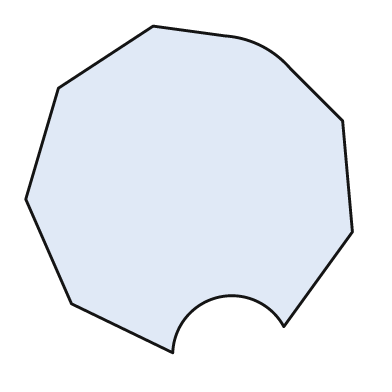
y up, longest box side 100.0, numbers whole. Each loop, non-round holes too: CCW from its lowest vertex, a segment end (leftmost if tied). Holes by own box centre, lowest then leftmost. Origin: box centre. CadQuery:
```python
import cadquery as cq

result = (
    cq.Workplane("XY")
    .moveTo(-5.0, -50.0)
    .threePointArc((9.0, -33.0), (29.0, -42.0))
    .lineTo(50.0, -13.0)
    .lineTo(47.0, 21.0)
    .lineTo(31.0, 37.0)
    .threePointArc((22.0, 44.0), (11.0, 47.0))
    .lineTo(-11.0, 50.0)
    .lineTo(-40.0, 31.0)
    .lineTo(-50.0, -3.0)
    .lineTo(-36.0, -35.0)
    .close()
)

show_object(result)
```